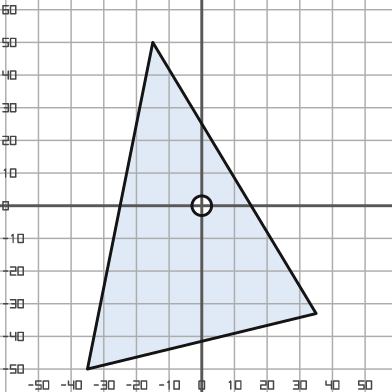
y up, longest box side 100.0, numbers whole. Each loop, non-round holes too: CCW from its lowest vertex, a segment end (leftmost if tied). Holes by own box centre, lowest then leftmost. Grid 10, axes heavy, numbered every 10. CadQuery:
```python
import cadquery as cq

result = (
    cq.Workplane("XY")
    .moveTo(-35.0, -50.0)
    .lineTo(35.0, -33.0)
    .lineTo(-15.0, 50.0)
    .close()
    .moveTo(0.0, 0.0)
    .circle(3.0)
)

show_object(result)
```